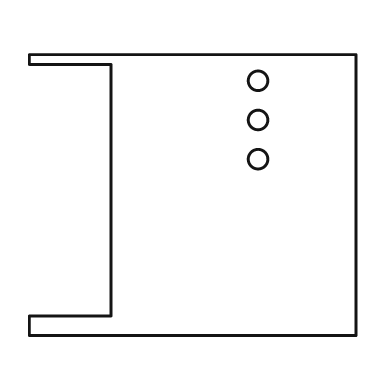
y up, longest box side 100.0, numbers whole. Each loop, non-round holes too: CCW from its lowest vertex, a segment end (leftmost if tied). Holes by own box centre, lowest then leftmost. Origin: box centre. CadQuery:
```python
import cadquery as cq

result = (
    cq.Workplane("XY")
    .moveTo(-50.0, -43.0)
    .lineTo(50.0, -43.0)
    .lineTo(50.0, 43.0)
    .lineTo(-50.0, 43.0)
    .lineTo(-50.0, 40.0)
    .lineTo(-25.0, 40.0)
    .lineTo(-25.0, -37.0)
    .lineTo(-50.0, -37.0)
    .close()
    .moveTo(20.0, 11.0)
    .circle(3.0)
    .moveTo(20.0, 23.0)
    .circle(3.0)
    .moveTo(20.0, 35.0)
    .circle(3.0)
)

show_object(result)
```